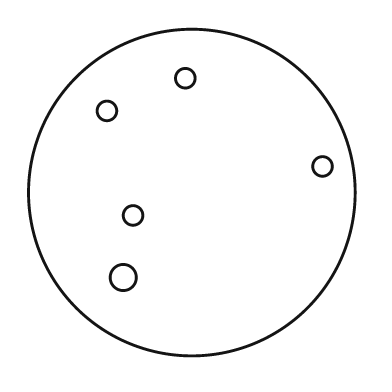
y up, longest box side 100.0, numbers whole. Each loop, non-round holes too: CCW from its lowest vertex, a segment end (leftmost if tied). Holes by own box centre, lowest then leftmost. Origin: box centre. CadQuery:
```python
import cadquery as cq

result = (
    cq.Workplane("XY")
    .moveTo(0.0, 0.0)
    .circle(50.0)
    .moveTo(-21.0, -26.0)
    .circle(4.0)
    .moveTo(-18.0, -7.0)
    .circle(3.0)
    .moveTo(40.0, 8.0)
    .circle(3.0)
    .moveTo(-26.0, 25.0)
    .circle(3.0)
    .moveTo(-2.0, 35.0)
    .circle(3.0)
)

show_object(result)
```